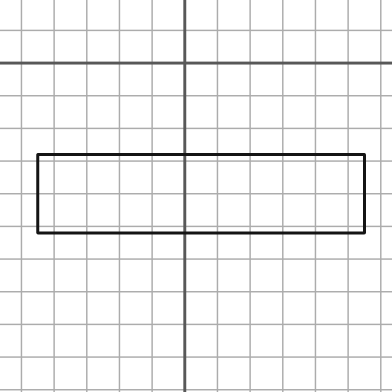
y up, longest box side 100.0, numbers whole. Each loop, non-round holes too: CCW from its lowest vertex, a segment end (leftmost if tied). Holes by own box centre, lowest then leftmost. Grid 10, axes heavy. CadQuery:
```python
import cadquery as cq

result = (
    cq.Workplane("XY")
    .moveTo(-45.0, -52.0)
    .lineTo(55.0, -52.0)
    .lineTo(55.0, -28.0)
    .lineTo(-45.0, -28.0)
    .close()
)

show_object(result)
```